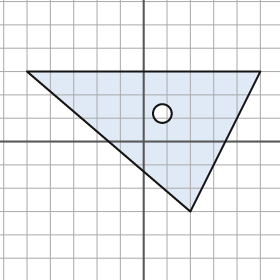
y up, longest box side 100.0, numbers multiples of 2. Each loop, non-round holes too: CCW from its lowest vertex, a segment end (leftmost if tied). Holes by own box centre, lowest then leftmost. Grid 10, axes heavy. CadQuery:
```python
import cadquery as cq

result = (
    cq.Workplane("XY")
    .moveTo(20.0, -30.0)
    .lineTo(50.0, 30.0)
    .lineTo(-50.0, 30.0)
    .close()
    .moveTo(8.0, 12.0)
    .circle(4.0)
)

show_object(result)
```